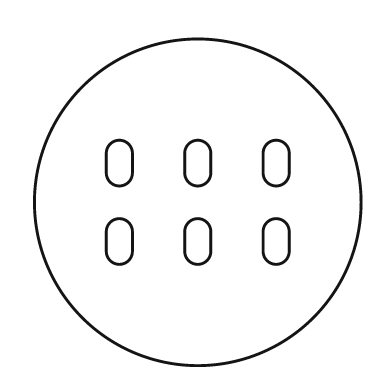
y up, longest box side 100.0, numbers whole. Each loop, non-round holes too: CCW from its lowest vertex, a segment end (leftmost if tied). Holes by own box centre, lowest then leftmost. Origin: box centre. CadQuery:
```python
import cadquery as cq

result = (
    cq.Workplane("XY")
    .moveTo(0.0, 0.0)
    .circle(50.0)
    .moveTo(-28.0, -15.0)
    .threePointArc((-24.0, -19.0), (-20.0, -15.0))
    .lineTo(-20.0, -9.0)
    .threePointArc((-24.0, -5.0), (-28.0, -9.0))
    .close()
    .moveTo(-4.0, -15.0)
    .threePointArc((0.0, -19.0), (4.0, -15.0))
    .lineTo(4.0, -9.0)
    .threePointArc((0.0, -5.0), (-4.0, -9.0))
    .close()
    .moveTo(20.0, -15.0)
    .threePointArc((24.0, -19.0), (28.0, -15.0))
    .lineTo(28.0, -9.0)
    .threePointArc((24.0, -5.0), (20.0, -9.0))
    .close()
    .moveTo(-28.0, 9.0)
    .threePointArc((-24.0, 5.0), (-20.0, 9.0))
    .lineTo(-20.0, 15.0)
    .threePointArc((-24.0, 19.0), (-28.0, 15.0))
    .close()
    .moveTo(-4.0, 9.0)
    .threePointArc((0.0, 5.0), (4.0, 9.0))
    .lineTo(4.0, 15.0)
    .threePointArc((0.0, 19.0), (-4.0, 15.0))
    .close()
    .moveTo(20.0, 9.0)
    .threePointArc((24.0, 5.0), (28.0, 9.0))
    .lineTo(28.0, 15.0)
    .threePointArc((24.0, 19.0), (20.0, 15.0))
    .close()
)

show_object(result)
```